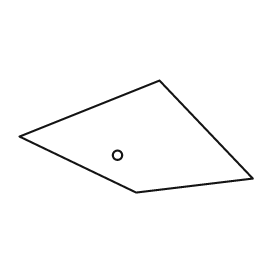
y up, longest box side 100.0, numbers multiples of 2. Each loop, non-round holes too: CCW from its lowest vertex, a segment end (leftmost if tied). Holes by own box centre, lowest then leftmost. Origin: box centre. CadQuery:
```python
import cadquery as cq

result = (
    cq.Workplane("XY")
    .moveTo(0.0, -24.0)
    .lineTo(50.0, -18.0)
    .lineTo(10.0, 24.0)
    .lineTo(-50.0, 0.0)
    .close()
    .moveTo(-8.0, -8.0)
    .circle(2.0)
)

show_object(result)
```